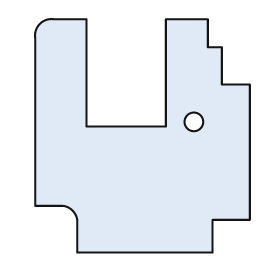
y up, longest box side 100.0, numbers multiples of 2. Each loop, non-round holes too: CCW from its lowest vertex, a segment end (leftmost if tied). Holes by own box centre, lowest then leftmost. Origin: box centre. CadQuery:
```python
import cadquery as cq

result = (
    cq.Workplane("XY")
    .moveTo(-28.0, -50.0)
    .lineTo(30.0, -50.0)
    .lineTo(30.0, -36.0)
    .lineTo(46.0, -36.0)
    .lineTo(46.0, 22.0)
    .lineTo(34.0, 22.0)
    .lineTo(34.0, 38.0)
    .lineTo(28.0, 38.0)
    .lineTo(28.0, 50.0)
    .lineTo(10.0, 50.0)
    .lineTo(10.0, 4.0)
    .lineTo(-24.0, 4.0)
    .lineTo(-24.0, 50.0)
    .lineTo(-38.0, 50.0)
    .threePointArc((-44.0, 48.0), (-46.0, 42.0))
    .lineTo(-46.0, -30.0)
    .lineTo(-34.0, -30.0)
    .threePointArc((-30.0, -32.0), (-28.0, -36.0))
    .close()
    .moveTo(22.0, 6.0)
    .circle(4.0)
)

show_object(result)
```